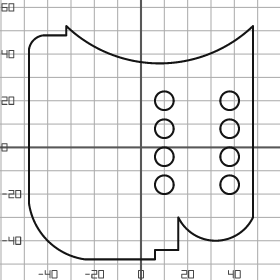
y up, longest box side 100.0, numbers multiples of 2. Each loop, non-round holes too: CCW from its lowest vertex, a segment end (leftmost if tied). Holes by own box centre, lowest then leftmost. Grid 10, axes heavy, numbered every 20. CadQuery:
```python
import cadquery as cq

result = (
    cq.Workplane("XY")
    .moveTo(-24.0, -48.0)
    .lineTo(6.0, -48.0)
    .lineTo(6.0, -44.0)
    .lineTo(16.0, -44.0)
    .lineTo(16.0, -30.0)
    .threePointArc((32.0, -40.0), (48.0, -30.0))
    .lineTo(48.0, 52.0)
    .threePointArc((8.0, 36.0), (-32.0, 52.0))
    .lineTo(-32.0, 48.0)
    .lineTo(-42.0, 48.0)
    .threePointArc((-46.0, 46.0), (-48.0, 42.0))
    .lineTo(-48.0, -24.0)
    .threePointArc((-40.0, -40.0), (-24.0, -48.0))
    .close()
    .moveTo(10.0, -16.0)
    .circle(4.0)
    .moveTo(38.0, -16.0)
    .circle(4.0)
    .moveTo(10.0, -4.0)
    .circle(4.0)
    .moveTo(38.0, -4.0)
    .circle(4.0)
    .moveTo(10.0, 8.0)
    .circle(4.0)
    .moveTo(38.0, 8.0)
    .circle(4.0)
    .moveTo(10.0, 20.0)
    .circle(4.0)
    .moveTo(38.0, 20.0)
    .circle(4.0)
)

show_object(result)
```